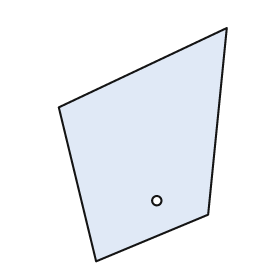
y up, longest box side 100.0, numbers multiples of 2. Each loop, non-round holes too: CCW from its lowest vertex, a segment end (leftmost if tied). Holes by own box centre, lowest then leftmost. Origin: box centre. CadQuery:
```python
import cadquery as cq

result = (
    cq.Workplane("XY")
    .moveTo(-20.0, -50.0)
    .lineTo(28.0, -30.0)
    .lineTo(36.0, 50.0)
    .lineTo(-36.0, 16.0)
    .close()
    .moveTo(6.0, -24.0)
    .circle(2.0)
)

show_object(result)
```